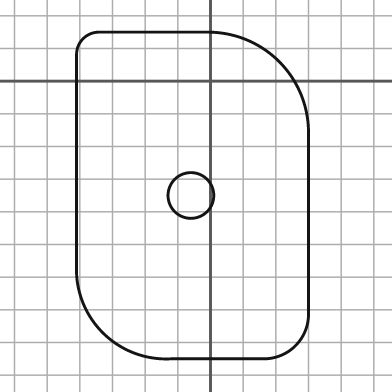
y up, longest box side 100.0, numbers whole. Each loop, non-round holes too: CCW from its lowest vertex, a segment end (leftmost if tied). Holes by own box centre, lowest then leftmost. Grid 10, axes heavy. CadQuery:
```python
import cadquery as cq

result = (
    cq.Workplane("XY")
    .moveTo(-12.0, -85.0)
    .lineTo(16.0, -85.0)
    .threePointArc((26.0, -81.0), (30.0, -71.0))
    .lineTo(30.0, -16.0)
    .threePointArc((21.0, 6.0), (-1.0, 15.0))
    .lineTo(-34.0, 15.0)
    .threePointArc((-39.0, 13.0), (-41.0, 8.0))
    .lineTo(-41.0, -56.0)
    .threePointArc((-33.0, -77.0), (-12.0, -85.0))
    .close()
    .moveTo(-6.0, -35.0)
    .circle(7.0)
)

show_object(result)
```